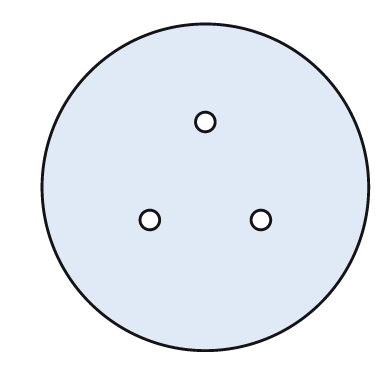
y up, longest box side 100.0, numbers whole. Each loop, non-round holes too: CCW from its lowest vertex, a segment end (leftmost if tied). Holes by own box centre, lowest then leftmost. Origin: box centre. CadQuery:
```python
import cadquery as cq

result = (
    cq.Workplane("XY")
    .moveTo(0.0, 0.0)
    .circle(50.0)
    .moveTo(-17.0, -10.0)
    .circle(3.0)
    .moveTo(17.0, -10.0)
    .circle(3.0)
    .moveTo(0.0, 20.0)
    .circle(3.0)
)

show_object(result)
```